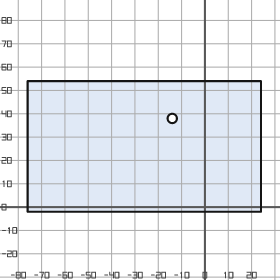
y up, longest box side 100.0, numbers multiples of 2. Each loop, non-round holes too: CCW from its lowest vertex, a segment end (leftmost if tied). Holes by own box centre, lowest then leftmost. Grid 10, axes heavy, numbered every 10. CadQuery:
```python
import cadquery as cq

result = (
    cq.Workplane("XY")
    .moveTo(-76.0, -2.0)
    .lineTo(24.0, -2.0)
    .lineTo(24.0, 54.0)
    .lineTo(-76.0, 54.0)
    .close()
    .moveTo(-14.0, 38.0)
    .circle(2.0)
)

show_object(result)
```